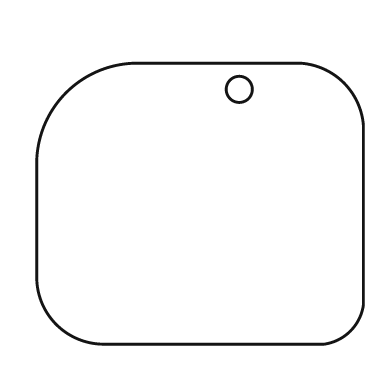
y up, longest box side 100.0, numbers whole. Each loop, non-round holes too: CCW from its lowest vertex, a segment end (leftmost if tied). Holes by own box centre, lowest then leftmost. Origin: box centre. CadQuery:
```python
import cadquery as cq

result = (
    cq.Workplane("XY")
    .moveTo(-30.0, -43.0)
    .lineTo(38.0, -43.0)
    .threePointArc((46.0, -39.0), (50.0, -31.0))
    .lineTo(50.0, 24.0)
    .threePointArc((44.0, 37.0), (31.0, 43.0))
    .lineTo(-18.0, 43.0)
    .threePointArc((-41.0, 34.0), (-50.0, 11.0))
    .lineTo(-50.0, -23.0)
    .threePointArc((-44.0, -37.0), (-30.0, -43.0))
    .close()
    .moveTo(12.0, 35.0)
    .circle(4.0)
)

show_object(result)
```